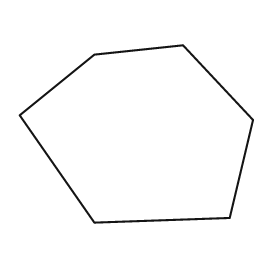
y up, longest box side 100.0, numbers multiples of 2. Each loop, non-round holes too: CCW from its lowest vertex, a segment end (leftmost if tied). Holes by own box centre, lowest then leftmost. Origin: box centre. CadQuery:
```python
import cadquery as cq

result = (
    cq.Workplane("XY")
    .moveTo(-18.0, -38.0)
    .lineTo(40.0, -36.0)
    .lineTo(50.0, 6.0)
    .lineTo(20.0, 38.0)
    .lineTo(-18.0, 34.0)
    .lineTo(-50.0, 8.0)
    .close()
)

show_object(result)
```